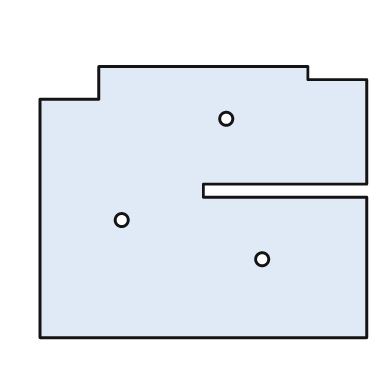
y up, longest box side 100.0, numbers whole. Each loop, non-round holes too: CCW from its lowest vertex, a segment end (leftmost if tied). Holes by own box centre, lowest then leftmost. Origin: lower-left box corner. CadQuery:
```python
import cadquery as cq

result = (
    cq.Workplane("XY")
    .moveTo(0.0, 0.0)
    .lineTo(100.0, 0.0)
    .lineTo(100.0, 43.0)
    .lineTo(50.0, 43.0)
    .lineTo(50.0, 47.0)
    .lineTo(100.0, 47.0)
    .lineTo(100.0, 79.0)
    .lineTo(82.0, 79.0)
    .lineTo(82.0, 83.0)
    .lineTo(18.0, 83.0)
    .lineTo(18.0, 73.0)
    .lineTo(0.0, 73.0)
    .close()
    .moveTo(68.0, 24.0)
    .circle(2.0)
    .moveTo(25.0, 36.0)
    .circle(2.0)
    .moveTo(57.0, 67.0)
    .circle(2.0)
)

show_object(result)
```